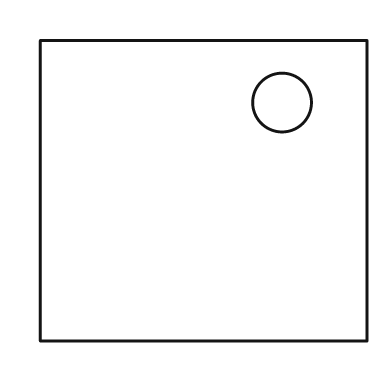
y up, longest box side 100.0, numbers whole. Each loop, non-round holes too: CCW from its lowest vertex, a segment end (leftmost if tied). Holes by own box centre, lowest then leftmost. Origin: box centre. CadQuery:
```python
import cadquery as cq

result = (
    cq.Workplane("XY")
    .moveTo(-50.0, -46.0)
    .lineTo(50.0, -46.0)
    .lineTo(50.0, 46.0)
    .lineTo(-50.0, 46.0)
    .close()
    .moveTo(24.0, 27.0)
    .circle(9.0)
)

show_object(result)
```